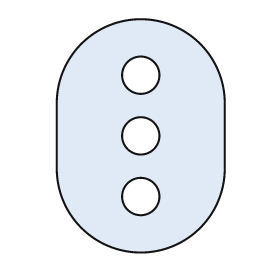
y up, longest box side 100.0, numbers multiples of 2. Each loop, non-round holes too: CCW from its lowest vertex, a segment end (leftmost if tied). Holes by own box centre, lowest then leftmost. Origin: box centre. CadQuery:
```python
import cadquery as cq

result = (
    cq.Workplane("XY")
    .moveTo(-36.0, -14.0)
    .threePointArc((0.0, -50.0), (36.0, -14.0))
    .lineTo(36.0, 14.0)
    .threePointArc((0.0, 50.0), (-36.0, 14.0))
    .close()
    .moveTo(0.0, -26.0)
    .circle(8.0)
    .moveTo(0.0, 0.0)
    .circle(8.0)
    .moveTo(0.0, 26.0)
    .circle(8.0)
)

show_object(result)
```